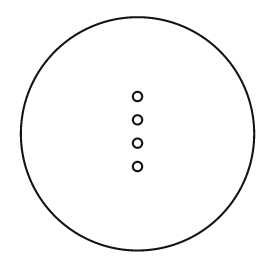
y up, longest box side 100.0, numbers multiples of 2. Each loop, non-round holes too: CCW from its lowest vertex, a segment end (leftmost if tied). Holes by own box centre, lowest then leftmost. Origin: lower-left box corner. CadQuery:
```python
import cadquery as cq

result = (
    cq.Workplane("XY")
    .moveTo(50.0, 50.0)
    .circle(50.0)
    .moveTo(50.0, 36.0)
    .circle(2.0)
    .moveTo(50.0, 46.0)
    .circle(2.0)
    .moveTo(50.0, 56.0)
    .circle(2.0)
    .moveTo(50.0, 66.0)
    .circle(2.0)
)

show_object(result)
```